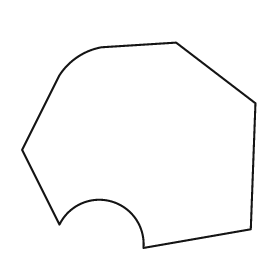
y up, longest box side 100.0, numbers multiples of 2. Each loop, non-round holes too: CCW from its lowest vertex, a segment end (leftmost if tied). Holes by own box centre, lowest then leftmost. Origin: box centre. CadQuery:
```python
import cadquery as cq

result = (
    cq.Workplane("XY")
    .moveTo(2.0, -44.0)
    .lineTo(48.0, -36.0)
    .lineTo(50.0, 18.0)
    .lineTo(16.0, 44.0)
    .lineTo(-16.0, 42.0)
    .threePointArc((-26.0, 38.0), (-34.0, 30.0))
    .lineTo(-50.0, -2.0)
    .lineTo(-34.0, -34.0)
    .threePointArc((-12.0, -24.0), (2.0, -44.0))
    .close()
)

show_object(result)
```